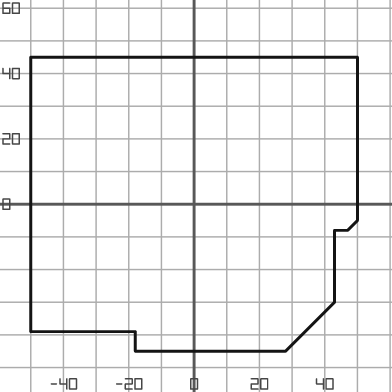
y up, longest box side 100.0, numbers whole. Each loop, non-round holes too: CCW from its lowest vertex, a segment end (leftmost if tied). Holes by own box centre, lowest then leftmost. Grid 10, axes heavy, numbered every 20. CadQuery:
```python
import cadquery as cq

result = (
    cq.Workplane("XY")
    .moveTo(-18.0, -45.0)
    .lineTo(28.0, -45.0)
    .lineTo(43.0, -30.0)
    .lineTo(43.0, -8.0)
    .lineTo(47.0, -8.0)
    .lineTo(50.0, -5.0)
    .lineTo(50.0, 45.0)
    .lineTo(-50.0, 45.0)
    .lineTo(-50.0, -39.0)
    .lineTo(-18.0, -39.0)
    .close()
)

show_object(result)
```